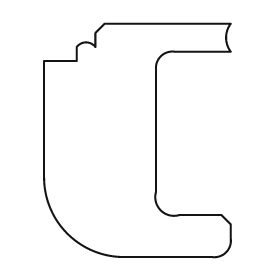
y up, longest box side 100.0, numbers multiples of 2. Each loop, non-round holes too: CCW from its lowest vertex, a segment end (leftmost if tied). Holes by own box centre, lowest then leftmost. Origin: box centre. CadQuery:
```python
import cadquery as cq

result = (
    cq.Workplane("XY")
    .moveTo(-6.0, -50.0)
    .lineTo(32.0, -50.0)
    .threePointArc((38.0, -48.0), (40.0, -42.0))
    .lineTo(40.0, -36.0)
    .lineTo(36.0, -32.0)
    .lineTo(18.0, -32.0)
    .threePointArc((10.0, -30.0), (8.0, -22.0))
    .lineTo(8.0, 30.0)
    .threePointArc((10.0, 36.0), (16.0, 38.0))
    .lineTo(40.0, 38.0)
    .threePointArc((38.0, 44.0), (40.0, 50.0))
    .lineTo(-14.0, 50.0)
    .lineTo(-18.0, 46.0)
    .lineTo(-18.0, 40.0)
    .threePointArc((-22.0, 42.0), (-26.0, 40.0))
    .lineTo(-26.0, 34.0)
    .lineTo(-40.0, 34.0)
    .lineTo(-40.0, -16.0)
    .threePointArc((-30.0, -40.0), (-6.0, -50.0))
    .close()
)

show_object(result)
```